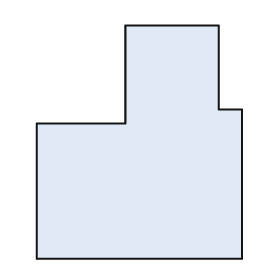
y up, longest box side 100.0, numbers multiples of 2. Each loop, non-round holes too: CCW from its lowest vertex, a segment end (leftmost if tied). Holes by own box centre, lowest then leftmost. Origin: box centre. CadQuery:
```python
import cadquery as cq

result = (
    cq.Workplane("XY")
    .moveTo(-44.0, -50.0)
    .lineTo(44.0, -50.0)
    .lineTo(44.0, 14.0)
    .lineTo(34.0, 14.0)
    .lineTo(34.0, 50.0)
    .lineTo(-6.0, 50.0)
    .lineTo(-6.0, 8.0)
    .lineTo(-44.0, 8.0)
    .close()
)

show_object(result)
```